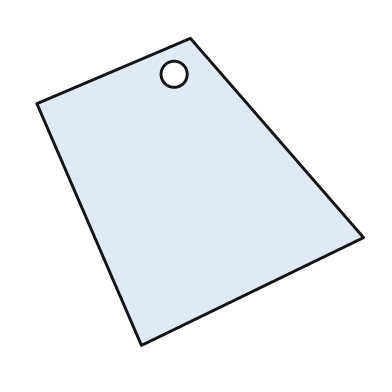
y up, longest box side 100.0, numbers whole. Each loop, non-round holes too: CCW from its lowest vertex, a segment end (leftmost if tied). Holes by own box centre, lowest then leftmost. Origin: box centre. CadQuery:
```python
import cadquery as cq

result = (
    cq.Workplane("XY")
    .moveTo(-18.0, -47.0)
    .lineTo(50.0, -14.0)
    .lineTo(-3.0, 47.0)
    .lineTo(-50.0, 27.0)
    .close()
    .moveTo(-8.0, 36.0)
    .circle(4.0)
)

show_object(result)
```